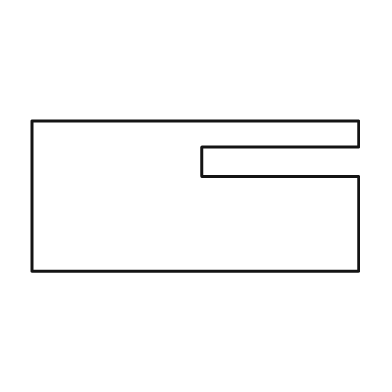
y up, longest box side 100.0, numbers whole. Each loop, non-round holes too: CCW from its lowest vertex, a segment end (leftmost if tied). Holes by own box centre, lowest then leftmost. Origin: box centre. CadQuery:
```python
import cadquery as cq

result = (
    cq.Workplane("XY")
    .moveTo(-50.0, -23.0)
    .lineTo(50.0, -23.0)
    .lineTo(50.0, 6.0)
    .lineTo(2.0, 6.0)
    .lineTo(2.0, 15.0)
    .lineTo(50.0, 15.0)
    .lineTo(50.0, 23.0)
    .lineTo(-50.0, 23.0)
    .close()
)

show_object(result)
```